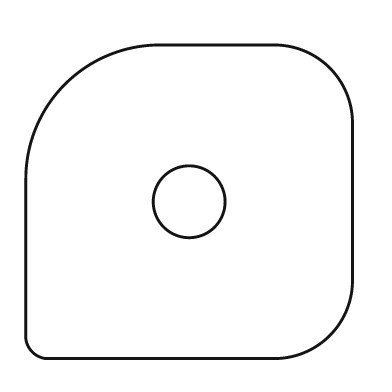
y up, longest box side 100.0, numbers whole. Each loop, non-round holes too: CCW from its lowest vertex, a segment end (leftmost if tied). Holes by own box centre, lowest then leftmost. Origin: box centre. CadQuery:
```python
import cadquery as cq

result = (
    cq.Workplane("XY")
    .moveTo(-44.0, -48.0)
    .lineTo(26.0, -48.0)
    .threePointArc((43.0, -41.0), (50.0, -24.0))
    .lineTo(50.0, 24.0)
    .threePointArc((43.0, 41.0), (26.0, 48.0))
    .lineTo(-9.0, 48.0)
    .threePointArc((-38.0, 36.0), (-50.0, 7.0))
    .lineTo(-50.0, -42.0)
    .threePointArc((-48.0, -46.0), (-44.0, -48.0))
    .close()
    .moveTo(0.0, 0.0)
    .circle(11.0)
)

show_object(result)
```